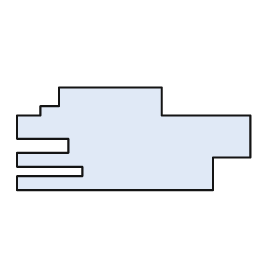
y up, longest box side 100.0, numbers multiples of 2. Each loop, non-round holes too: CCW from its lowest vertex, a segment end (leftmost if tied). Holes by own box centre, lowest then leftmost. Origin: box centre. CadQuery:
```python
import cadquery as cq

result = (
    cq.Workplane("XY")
    .moveTo(-50.0, -22.0)
    .lineTo(34.0, -22.0)
    .lineTo(34.0, -8.0)
    .lineTo(50.0, -8.0)
    .lineTo(50.0, 10.0)
    .lineTo(12.0, 10.0)
    .lineTo(12.0, 22.0)
    .lineTo(-32.0, 22.0)
    .lineTo(-32.0, 14.0)
    .lineTo(-40.0, 14.0)
    .lineTo(-40.0, 10.0)
    .lineTo(-50.0, 10.0)
    .lineTo(-50.0, 0.0)
    .lineTo(-28.0, 0.0)
    .lineTo(-28.0, -6.0)
    .lineTo(-50.0, -6.0)
    .lineTo(-50.0, -12.0)
    .lineTo(-22.0, -12.0)
    .lineTo(-22.0, -16.0)
    .lineTo(-50.0, -16.0)
    .close()
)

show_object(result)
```